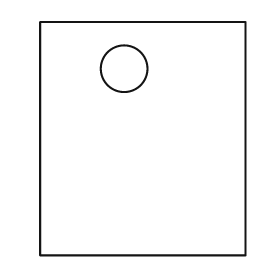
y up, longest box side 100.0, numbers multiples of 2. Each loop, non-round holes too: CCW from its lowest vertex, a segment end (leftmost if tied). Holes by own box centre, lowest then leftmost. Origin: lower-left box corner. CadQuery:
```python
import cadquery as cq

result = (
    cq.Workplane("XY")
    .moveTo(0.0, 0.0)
    .lineTo(88.0, 0.0)
    .lineTo(88.0, 100.0)
    .lineTo(0.0, 100.0)
    .close()
    .moveTo(36.0, 80.0)
    .circle(10.0)
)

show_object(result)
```